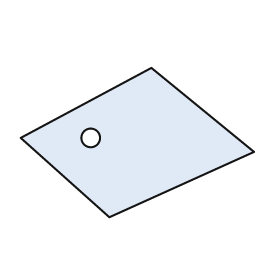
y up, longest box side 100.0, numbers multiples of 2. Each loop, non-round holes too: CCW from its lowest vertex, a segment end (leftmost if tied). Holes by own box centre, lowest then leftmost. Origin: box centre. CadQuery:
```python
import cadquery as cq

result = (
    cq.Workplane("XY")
    .moveTo(-12.0, -32.0)
    .lineTo(50.0, -4.0)
    .lineTo(6.0, 32.0)
    .lineTo(-50.0, 2.0)
    .close()
    .moveTo(-20.0, 2.0)
    .circle(4.0)
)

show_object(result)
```